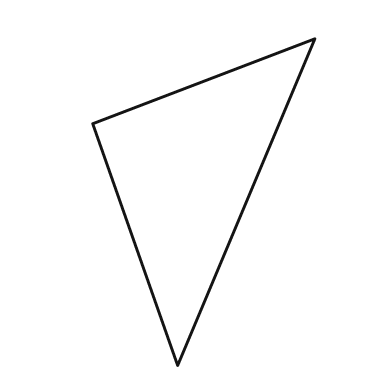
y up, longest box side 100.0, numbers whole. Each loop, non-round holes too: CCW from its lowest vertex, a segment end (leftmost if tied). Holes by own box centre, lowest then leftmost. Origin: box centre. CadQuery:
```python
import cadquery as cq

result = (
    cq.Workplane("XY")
    .moveTo(-8.0, -50.0)
    .lineTo(34.0, 50.0)
    .lineTo(-34.0, 24.0)
    .close()
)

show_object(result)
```